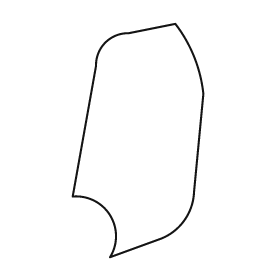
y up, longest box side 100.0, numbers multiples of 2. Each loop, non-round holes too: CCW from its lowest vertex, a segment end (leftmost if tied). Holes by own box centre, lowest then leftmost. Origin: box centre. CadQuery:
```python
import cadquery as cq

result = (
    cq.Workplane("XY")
    .moveTo(-12.0, -50.0)
    .lineTo(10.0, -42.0)
    .threePointArc((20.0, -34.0), (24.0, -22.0))
    .lineTo(28.0, 20.0)
    .threePointArc((24.0, 36.0), (16.0, 50.0))
    .lineTo(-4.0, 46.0)
    .threePointArc((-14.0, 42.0), (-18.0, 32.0))
    .lineTo(-28.0, -24.0)
    .threePointArc((-12.0, -32.0), (-12.0, -50.0))
    .close()
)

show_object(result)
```